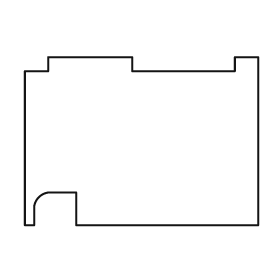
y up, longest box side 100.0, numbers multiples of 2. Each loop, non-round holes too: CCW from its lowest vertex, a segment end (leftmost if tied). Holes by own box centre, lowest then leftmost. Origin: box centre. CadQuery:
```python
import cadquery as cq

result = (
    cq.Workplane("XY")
    .moveTo(-50.0, -36.0)
    .lineTo(-46.0, -36.0)
    .lineTo(-46.0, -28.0)
    .threePointArc((-44.0, -24.0), (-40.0, -22.0))
    .lineTo(-28.0, -22.0)
    .lineTo(-28.0, -36.0)
    .lineTo(50.0, -36.0)
    .lineTo(50.0, 36.0)
    .lineTo(40.0, 36.0)
    .lineTo(40.0, 30.0)
    .lineTo(-4.0, 30.0)
    .lineTo(-4.0, 36.0)
    .lineTo(-40.0, 36.0)
    .lineTo(-40.0, 30.0)
    .lineTo(-50.0, 30.0)
    .close()
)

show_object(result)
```